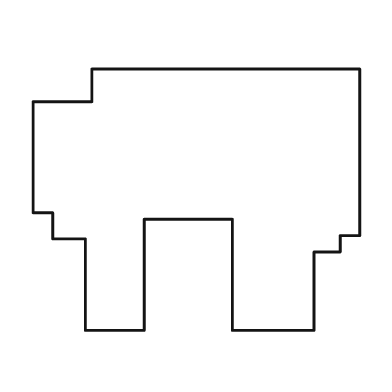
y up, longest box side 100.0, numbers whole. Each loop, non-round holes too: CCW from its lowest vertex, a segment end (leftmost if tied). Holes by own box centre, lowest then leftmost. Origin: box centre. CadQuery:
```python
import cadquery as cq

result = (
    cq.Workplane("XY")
    .moveTo(-34.0, -40.0)
    .lineTo(-16.0, -40.0)
    .lineTo(-16.0, -6.0)
    .lineTo(11.0, -6.0)
    .lineTo(11.0, -40.0)
    .lineTo(36.0, -40.0)
    .lineTo(36.0, -16.0)
    .lineTo(44.0, -16.0)
    .lineTo(44.0, -11.0)
    .lineTo(50.0, -11.0)
    .lineTo(50.0, 40.0)
    .lineTo(-32.0, 40.0)
    .lineTo(-32.0, 30.0)
    .lineTo(-50.0, 30.0)
    .lineTo(-50.0, -4.0)
    .lineTo(-44.0, -4.0)
    .lineTo(-44.0, -12.0)
    .lineTo(-34.0, -12.0)
    .close()
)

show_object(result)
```